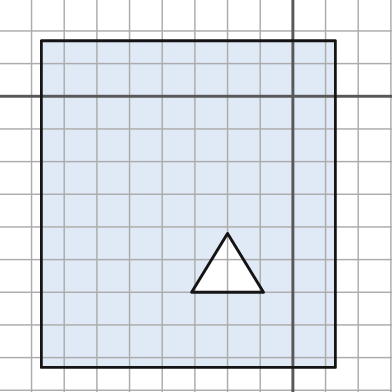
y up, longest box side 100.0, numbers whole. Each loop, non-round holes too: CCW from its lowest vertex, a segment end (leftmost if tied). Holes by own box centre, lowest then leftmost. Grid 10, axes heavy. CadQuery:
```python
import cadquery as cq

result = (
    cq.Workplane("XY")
    .moveTo(-77.0, -83.0)
    .lineTo(13.0, -83.0)
    .lineTo(13.0, 17.0)
    .lineTo(-77.0, 17.0)
    .close()
    .moveTo(-31.0, -60.0)
    .lineTo(-9.0, -60.0)
    .lineTo(-20.0, -42.0)
    .close()
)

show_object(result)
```